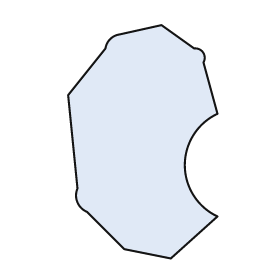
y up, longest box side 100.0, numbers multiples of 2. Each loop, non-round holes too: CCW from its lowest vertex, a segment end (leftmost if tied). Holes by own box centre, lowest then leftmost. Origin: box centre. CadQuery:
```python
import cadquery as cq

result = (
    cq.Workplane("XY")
    .moveTo(12.0, -50.0)
    .lineTo(32.0, -32.0)
    .threePointArc((18.0, -10.0), (32.0, 12.0))
    .lineTo(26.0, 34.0)
    .threePointArc((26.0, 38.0), (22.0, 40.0))
    .lineTo(8.0, 50.0)
    .lineTo(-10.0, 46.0)
    .threePointArc((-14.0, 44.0), (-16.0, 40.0))
    .lineTo(-32.0, 20.0)
    .lineTo(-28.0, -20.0)
    .threePointArc((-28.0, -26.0), (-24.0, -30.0))
    .lineTo(-8.0, -46.0)
    .close()
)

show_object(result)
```